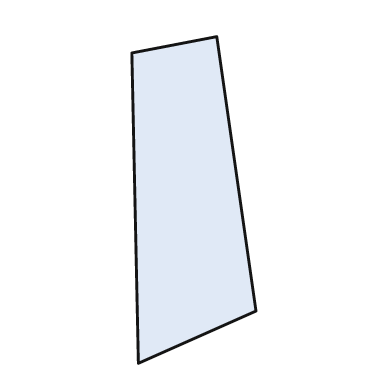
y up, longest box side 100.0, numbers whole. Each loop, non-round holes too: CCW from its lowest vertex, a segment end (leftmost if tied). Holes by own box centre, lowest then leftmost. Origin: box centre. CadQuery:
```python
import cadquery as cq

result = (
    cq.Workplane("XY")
    .moveTo(-17.0, -50.0)
    .lineTo(19.0, -34.0)
    .lineTo(7.0, 50.0)
    .lineTo(-19.0, 45.0)
    .close()
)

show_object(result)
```